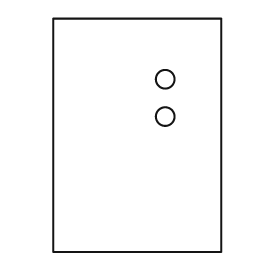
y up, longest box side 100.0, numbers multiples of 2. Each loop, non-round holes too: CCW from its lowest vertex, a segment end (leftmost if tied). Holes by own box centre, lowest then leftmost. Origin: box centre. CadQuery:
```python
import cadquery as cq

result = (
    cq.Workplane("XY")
    .moveTo(-36.0, -50.0)
    .lineTo(36.0, -50.0)
    .lineTo(36.0, 50.0)
    .lineTo(-36.0, 50.0)
    .close()
    .moveTo(12.0, 8.0)
    .circle(4.0)
    .moveTo(12.0, 24.0)
    .circle(4.0)
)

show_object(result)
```